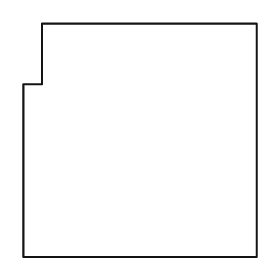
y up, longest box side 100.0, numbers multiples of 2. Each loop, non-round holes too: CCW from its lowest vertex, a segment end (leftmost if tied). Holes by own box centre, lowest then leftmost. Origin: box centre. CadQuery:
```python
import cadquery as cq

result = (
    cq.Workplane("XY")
    .moveTo(-50.0, -50.0)
    .lineTo(50.0, -50.0)
    .lineTo(50.0, 50.0)
    .lineTo(-42.0, 50.0)
    .lineTo(-42.0, 24.0)
    .lineTo(-50.0, 24.0)
    .close()
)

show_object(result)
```